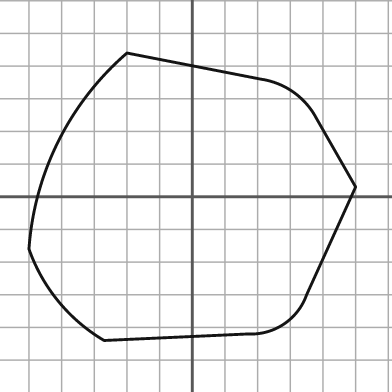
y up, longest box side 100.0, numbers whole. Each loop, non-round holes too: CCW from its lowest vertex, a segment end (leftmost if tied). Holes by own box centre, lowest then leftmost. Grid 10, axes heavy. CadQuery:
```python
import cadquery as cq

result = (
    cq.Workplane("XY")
    .moveTo(-27.0, -44.0)
    .lineTo(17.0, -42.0)
    .threePointArc((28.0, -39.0), (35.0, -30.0))
    .lineTo(50.0, 3.0)
    .lineTo(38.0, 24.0)
    .threePointArc((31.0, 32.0), (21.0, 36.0))
    .lineTo(-20.0, 44.0)
    .threePointArc((-41.0, 17.0), (-50.0, -16.0))
    .threePointArc((-41.0, -32.0), (-27.0, -44.0))
    .close()
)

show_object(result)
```